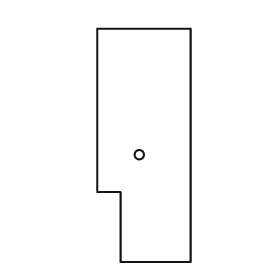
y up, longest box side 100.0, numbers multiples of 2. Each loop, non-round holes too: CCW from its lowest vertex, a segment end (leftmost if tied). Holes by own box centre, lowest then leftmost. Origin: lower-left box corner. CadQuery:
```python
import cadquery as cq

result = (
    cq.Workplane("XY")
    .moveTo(10.0, 0.0)
    .lineTo(40.0, 0.0)
    .lineTo(40.0, 100.0)
    .lineTo(0.0, 100.0)
    .lineTo(0.0, 30.0)
    .lineTo(10.0, 30.0)
    .close()
    .moveTo(18.0, 46.0)
    .circle(2.0)
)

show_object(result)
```